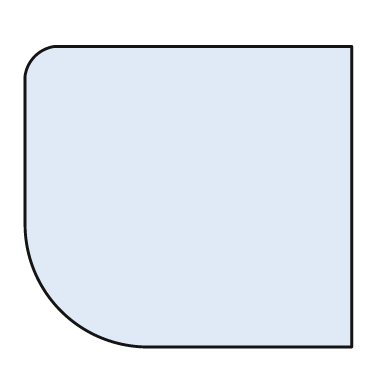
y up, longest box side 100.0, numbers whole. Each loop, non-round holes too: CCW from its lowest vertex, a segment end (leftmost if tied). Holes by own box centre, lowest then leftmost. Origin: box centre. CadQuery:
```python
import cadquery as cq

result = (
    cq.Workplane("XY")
    .moveTo(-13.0, -46.0)
    .lineTo(50.0, -46.0)
    .lineTo(50.0, 46.0)
    .lineTo(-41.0, 46.0)
    .threePointArc((-47.0, 43.0), (-50.0, 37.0))
    .lineTo(-50.0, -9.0)
    .threePointArc((-39.0, -35.0), (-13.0, -46.0))
    .close()
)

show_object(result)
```